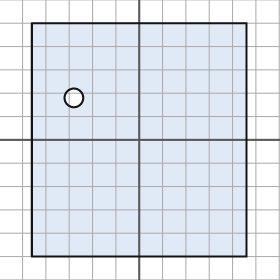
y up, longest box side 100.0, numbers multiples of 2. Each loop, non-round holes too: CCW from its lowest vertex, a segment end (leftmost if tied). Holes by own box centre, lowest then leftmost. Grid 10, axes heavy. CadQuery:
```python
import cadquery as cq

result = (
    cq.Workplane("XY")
    .moveTo(-46.0, -50.0)
    .lineTo(46.0, -50.0)
    .lineTo(46.0, 50.0)
    .lineTo(-46.0, 50.0)
    .close()
    .moveTo(-28.0, 18.0)
    .circle(4.0)
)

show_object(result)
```